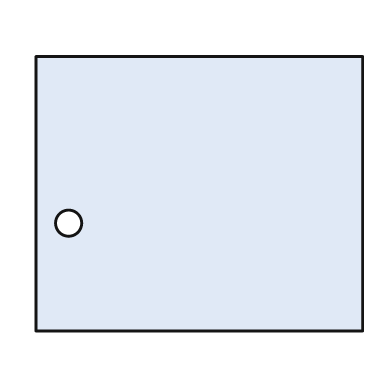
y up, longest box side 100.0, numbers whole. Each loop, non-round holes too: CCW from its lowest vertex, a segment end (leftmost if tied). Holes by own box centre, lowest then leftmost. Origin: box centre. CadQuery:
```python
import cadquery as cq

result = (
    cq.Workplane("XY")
    .moveTo(-50.0, -42.0)
    .lineTo(50.0, -42.0)
    .lineTo(50.0, 42.0)
    .lineTo(-50.0, 42.0)
    .close()
    .moveTo(-40.0, -9.0)
    .circle(4.0)
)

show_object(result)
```